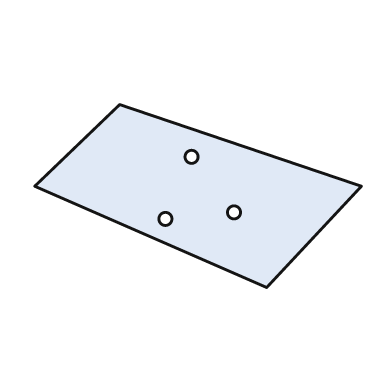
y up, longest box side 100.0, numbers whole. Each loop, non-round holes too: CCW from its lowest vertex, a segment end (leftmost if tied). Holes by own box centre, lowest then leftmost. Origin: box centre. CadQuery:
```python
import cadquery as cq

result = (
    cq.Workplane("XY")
    .moveTo(21.0, -28.0)
    .lineTo(50.0, 3.0)
    .lineTo(-24.0, 28.0)
    .lineTo(-50.0, 3.0)
    .close()
    .moveTo(-10.0, -7.0)
    .circle(2.0)
    .moveTo(11.0, -5.0)
    .circle(2.0)
    .moveTo(-2.0, 12.0)
    .circle(2.0)
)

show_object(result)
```